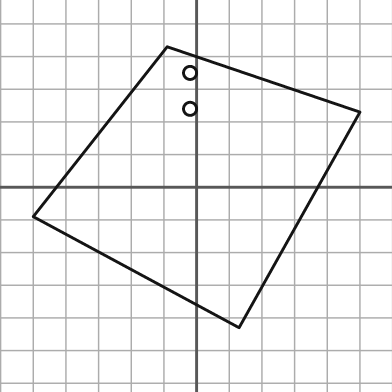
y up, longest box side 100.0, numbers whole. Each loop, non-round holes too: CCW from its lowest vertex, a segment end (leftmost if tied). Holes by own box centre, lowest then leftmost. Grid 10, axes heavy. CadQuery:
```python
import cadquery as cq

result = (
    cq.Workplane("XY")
    .moveTo(13.0, -43.0)
    .lineTo(50.0, 23.0)
    .lineTo(-9.0, 43.0)
    .lineTo(-50.0, -9.0)
    .close()
    .moveTo(-2.0, 24.0)
    .circle(2.0)
    .moveTo(-2.0, 35.0)
    .circle(2.0)
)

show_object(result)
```